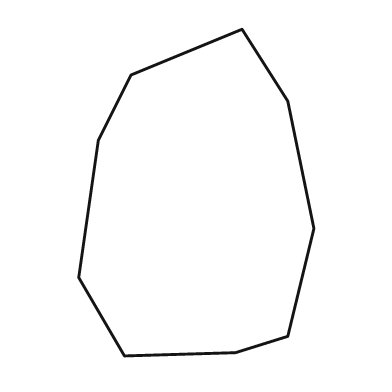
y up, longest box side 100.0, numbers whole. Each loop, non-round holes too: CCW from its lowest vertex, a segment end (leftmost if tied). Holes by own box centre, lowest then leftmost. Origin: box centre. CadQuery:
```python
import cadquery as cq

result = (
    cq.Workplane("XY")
    .moveTo(-22.0, -50.0)
    .lineTo(12.0, -49.0)
    .lineTo(28.0, -44.0)
    .lineTo(36.0, -11.0)
    .lineTo(28.0, 28.0)
    .lineTo(14.0, 50.0)
    .lineTo(-20.0, 36.0)
    .lineTo(-30.0, 16.0)
    .lineTo(-36.0, -26.0)
    .close()
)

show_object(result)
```